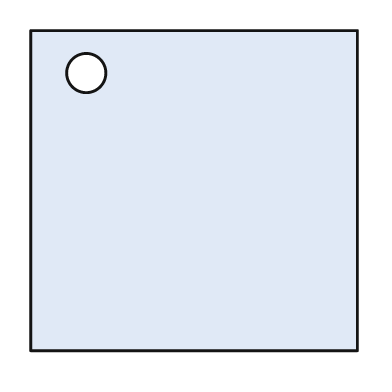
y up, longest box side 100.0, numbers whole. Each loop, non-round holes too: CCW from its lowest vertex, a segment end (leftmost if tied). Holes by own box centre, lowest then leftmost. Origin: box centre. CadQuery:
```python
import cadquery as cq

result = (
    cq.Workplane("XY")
    .moveTo(-50.0, -49.0)
    .lineTo(50.0, -49.0)
    .lineTo(50.0, 49.0)
    .lineTo(-50.0, 49.0)
    .close()
    .moveTo(-33.0, 36.0)
    .circle(6.0)
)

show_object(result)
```